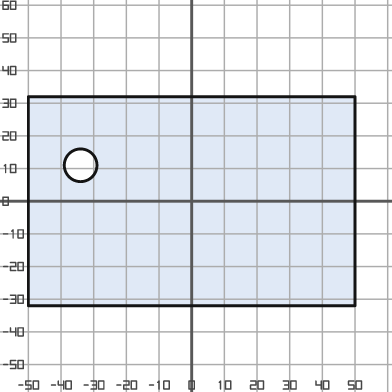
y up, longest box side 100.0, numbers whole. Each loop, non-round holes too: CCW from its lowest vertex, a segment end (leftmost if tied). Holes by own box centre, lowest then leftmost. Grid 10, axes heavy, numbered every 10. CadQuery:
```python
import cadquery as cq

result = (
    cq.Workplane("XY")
    .moveTo(-50.0, -32.0)
    .lineTo(50.0, -32.0)
    .lineTo(50.0, 32.0)
    .lineTo(-50.0, 32.0)
    .close()
    .moveTo(-34.0, 11.0)
    .circle(5.0)
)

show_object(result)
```